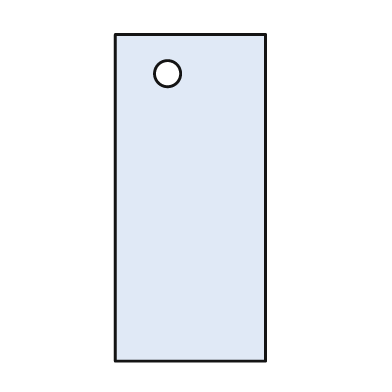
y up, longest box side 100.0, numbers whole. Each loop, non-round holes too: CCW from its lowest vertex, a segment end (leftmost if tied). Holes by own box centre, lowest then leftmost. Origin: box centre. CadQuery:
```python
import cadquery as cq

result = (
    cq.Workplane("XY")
    .moveTo(-23.0, -50.0)
    .lineTo(23.0, -50.0)
    .lineTo(23.0, 50.0)
    .lineTo(-23.0, 50.0)
    .close()
    .moveTo(-7.0, 38.0)
    .circle(4.0)
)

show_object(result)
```